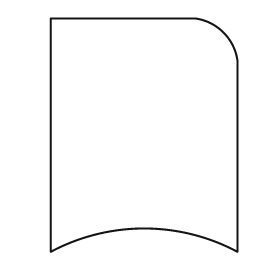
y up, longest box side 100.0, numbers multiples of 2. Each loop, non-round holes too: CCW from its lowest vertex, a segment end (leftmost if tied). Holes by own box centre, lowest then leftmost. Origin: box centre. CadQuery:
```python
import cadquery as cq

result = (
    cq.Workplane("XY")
    .moveTo(-40.0, -50.0)
    .threePointArc((0.0, -40.0), (40.0, -50.0))
    .lineTo(40.0, 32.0)
    .threePointArc((34.0, 44.0), (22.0, 50.0))
    .lineTo(-40.0, 50.0)
    .close()
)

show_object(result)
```